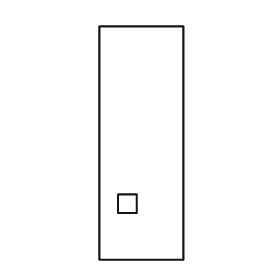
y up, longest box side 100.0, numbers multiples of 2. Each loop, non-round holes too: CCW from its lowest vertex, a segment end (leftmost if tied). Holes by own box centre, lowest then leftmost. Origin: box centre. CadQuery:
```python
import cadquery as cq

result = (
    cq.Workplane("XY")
    .moveTo(-18.0, -50.0)
    .lineTo(18.0, -50.0)
    .lineTo(18.0, 50.0)
    .lineTo(-18.0, 50.0)
    .close()
    .moveTo(-10.0, -30.0)
    .lineTo(-2.0, -30.0)
    .lineTo(-2.0, -22.0)
    .lineTo(-10.0, -22.0)
    .close()
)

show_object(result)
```